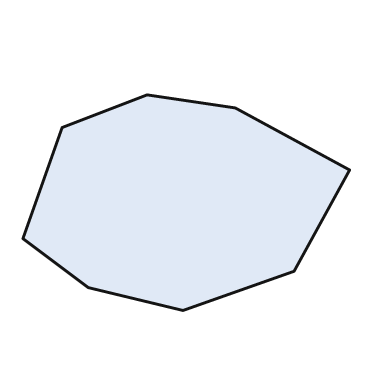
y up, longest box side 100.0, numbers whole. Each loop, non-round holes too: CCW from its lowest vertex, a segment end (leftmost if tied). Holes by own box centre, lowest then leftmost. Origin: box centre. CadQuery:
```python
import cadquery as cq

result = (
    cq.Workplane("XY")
    .moveTo(-1.0, -33.0)
    .lineTo(33.0, -21.0)
    .lineTo(50.0, 10.0)
    .lineTo(15.0, 29.0)
    .lineTo(-12.0, 33.0)
    .lineTo(-38.0, 23.0)
    .lineTo(-50.0, -11.0)
    .lineTo(-30.0, -26.0)
    .close()
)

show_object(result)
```